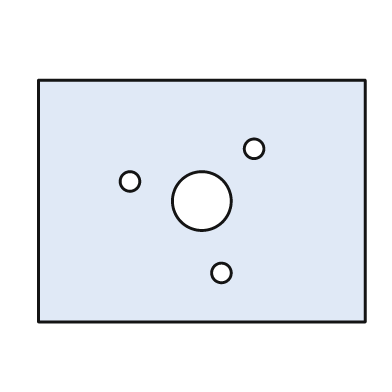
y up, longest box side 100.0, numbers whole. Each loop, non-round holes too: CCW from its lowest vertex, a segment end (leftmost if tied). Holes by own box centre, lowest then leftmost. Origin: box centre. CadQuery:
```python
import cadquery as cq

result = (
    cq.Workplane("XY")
    .moveTo(-50.0, -37.0)
    .lineTo(50.0, -37.0)
    .lineTo(50.0, 37.0)
    .lineTo(-50.0, 37.0)
    .close()
    .moveTo(6.0, -22.0)
    .circle(3.0)
    .moveTo(0.0, 0.0)
    .circle(9.0)
    .moveTo(-22.0, 6.0)
    .circle(3.0)
    .moveTo(16.0, 16.0)
    .circle(3.0)
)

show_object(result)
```